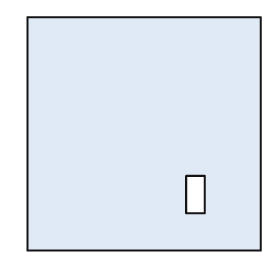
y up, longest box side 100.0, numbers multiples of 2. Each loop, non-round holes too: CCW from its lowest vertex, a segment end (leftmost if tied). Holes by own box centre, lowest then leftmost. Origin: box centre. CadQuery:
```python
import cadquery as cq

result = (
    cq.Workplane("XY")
    .moveTo(-50.0, -50.0)
    .lineTo(50.0, -50.0)
    .lineTo(50.0, 50.0)
    .lineTo(-50.0, 50.0)
    .close()
    .moveTo(18.0, -34.0)
    .lineTo(26.0, -34.0)
    .lineTo(26.0, -18.0)
    .lineTo(18.0, -18.0)
    .close()
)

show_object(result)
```